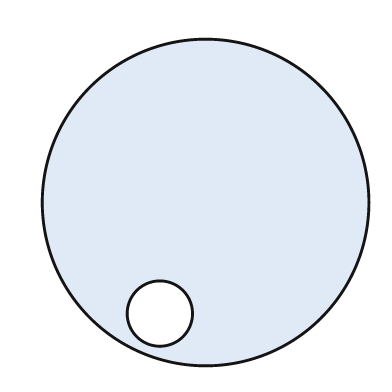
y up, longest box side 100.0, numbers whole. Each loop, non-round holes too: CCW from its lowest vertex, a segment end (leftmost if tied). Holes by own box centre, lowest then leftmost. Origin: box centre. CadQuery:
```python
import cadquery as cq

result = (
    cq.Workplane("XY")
    .moveTo(0.0, 0.0)
    .circle(50.0)
    .moveTo(-14.0, -34.0)
    .circle(10.0)
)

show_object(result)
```